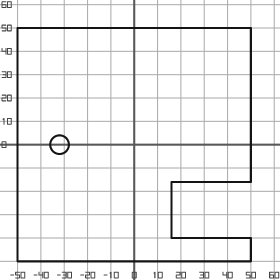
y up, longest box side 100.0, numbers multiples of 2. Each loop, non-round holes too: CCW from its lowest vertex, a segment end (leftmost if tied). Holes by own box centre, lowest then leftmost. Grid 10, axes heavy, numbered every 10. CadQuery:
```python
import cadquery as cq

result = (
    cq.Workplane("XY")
    .moveTo(-50.0, -50.0)
    .lineTo(50.0, -50.0)
    .lineTo(50.0, -40.0)
    .lineTo(16.0, -40.0)
    .lineTo(16.0, -16.0)
    .lineTo(50.0, -16.0)
    .lineTo(50.0, 50.0)
    .lineTo(-50.0, 50.0)
    .close()
    .moveTo(-32.0, 0.0)
    .circle(4.0)
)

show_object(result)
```